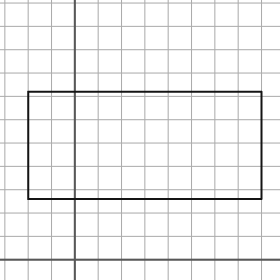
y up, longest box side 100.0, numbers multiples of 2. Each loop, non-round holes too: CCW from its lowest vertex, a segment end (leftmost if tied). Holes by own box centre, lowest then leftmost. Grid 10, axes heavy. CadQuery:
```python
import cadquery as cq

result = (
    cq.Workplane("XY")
    .moveTo(-20.0, 26.0)
    .lineTo(80.0, 26.0)
    .lineTo(80.0, 72.0)
    .lineTo(-20.0, 72.0)
    .close()
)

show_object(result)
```